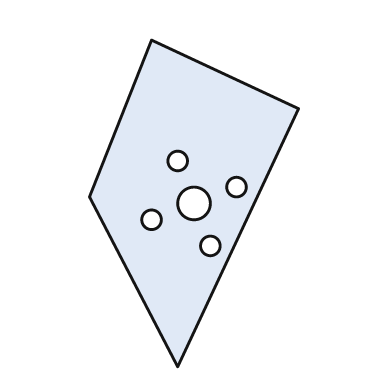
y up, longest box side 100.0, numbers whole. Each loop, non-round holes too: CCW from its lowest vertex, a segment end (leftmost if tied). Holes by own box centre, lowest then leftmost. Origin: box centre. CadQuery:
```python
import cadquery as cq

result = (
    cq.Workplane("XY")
    .moveTo(-5.0, -50.0)
    .lineTo(32.0, 29.0)
    .lineTo(-13.0, 50.0)
    .lineTo(-32.0, 2.0)
    .close()
    .moveTo(5.0, -13.0)
    .circle(3.0)
    .moveTo(-13.0, -5.0)
    .circle(3.0)
    .moveTo(0.0, 0.0)
    .circle(5.0)
    .moveTo(13.0, 5.0)
    .circle(3.0)
    .moveTo(-5.0, 13.0)
    .circle(3.0)
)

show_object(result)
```